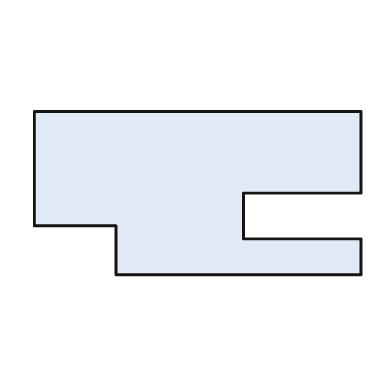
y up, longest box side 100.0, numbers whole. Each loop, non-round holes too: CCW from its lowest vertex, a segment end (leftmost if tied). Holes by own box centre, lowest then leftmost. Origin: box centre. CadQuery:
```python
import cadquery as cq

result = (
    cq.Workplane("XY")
    .moveTo(-25.0, -25.0)
    .lineTo(50.0, -25.0)
    .lineTo(50.0, -14.0)
    .lineTo(14.0, -14.0)
    .lineTo(14.0, 0.0)
    .lineTo(50.0, 0.0)
    .lineTo(50.0, 25.0)
    .lineTo(-50.0, 25.0)
    .lineTo(-50.0, -10.0)
    .lineTo(-25.0, -10.0)
    .close()
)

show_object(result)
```